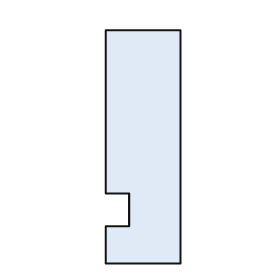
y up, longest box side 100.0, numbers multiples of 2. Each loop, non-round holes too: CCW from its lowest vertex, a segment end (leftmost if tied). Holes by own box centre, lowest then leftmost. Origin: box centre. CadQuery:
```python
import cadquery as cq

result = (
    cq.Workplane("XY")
    .moveTo(-16.0, -50.0)
    .lineTo(16.0, -50.0)
    .lineTo(16.0, 50.0)
    .lineTo(-16.0, 50.0)
    .lineTo(-16.0, -20.0)
    .lineTo(-6.0, -20.0)
    .lineTo(-6.0, -34.0)
    .lineTo(-16.0, -34.0)
    .close()
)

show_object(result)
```